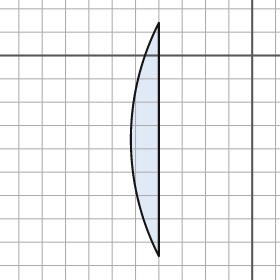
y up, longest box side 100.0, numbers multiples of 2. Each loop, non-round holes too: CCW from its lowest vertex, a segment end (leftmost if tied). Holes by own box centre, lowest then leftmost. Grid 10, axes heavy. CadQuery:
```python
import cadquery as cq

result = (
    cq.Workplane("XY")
    .moveTo(-40.0, -86.0)
    .lineTo(-40.0, 14.0)
    .threePointArc((-52.0, -36.0), (-40.0, -86.0))
    .close()
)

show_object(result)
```